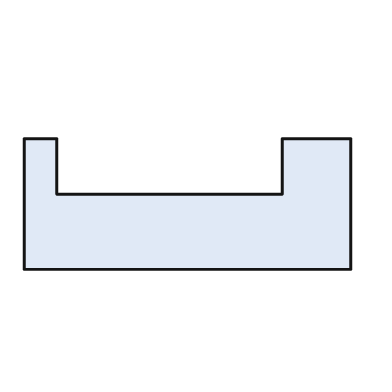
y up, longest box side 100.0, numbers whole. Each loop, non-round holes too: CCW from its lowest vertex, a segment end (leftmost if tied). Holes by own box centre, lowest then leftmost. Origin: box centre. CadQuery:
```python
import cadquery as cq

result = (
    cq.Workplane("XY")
    .moveTo(-50.0, -20.0)
    .lineTo(50.0, -20.0)
    .lineTo(50.0, 20.0)
    .lineTo(29.0, 20.0)
    .lineTo(29.0, 3.0)
    .lineTo(-40.0, 3.0)
    .lineTo(-40.0, 20.0)
    .lineTo(-50.0, 20.0)
    .close()
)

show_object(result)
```